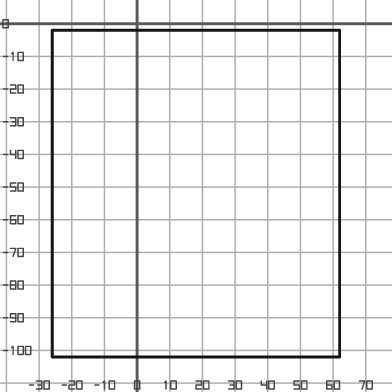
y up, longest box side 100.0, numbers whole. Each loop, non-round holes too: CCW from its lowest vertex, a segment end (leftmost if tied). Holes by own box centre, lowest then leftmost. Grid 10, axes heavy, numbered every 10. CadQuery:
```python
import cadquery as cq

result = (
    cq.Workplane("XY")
    .moveTo(-26.0, -102.0)
    .lineTo(62.0, -102.0)
    .lineTo(62.0, -2.0)
    .lineTo(-26.0, -2.0)
    .close()
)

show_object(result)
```